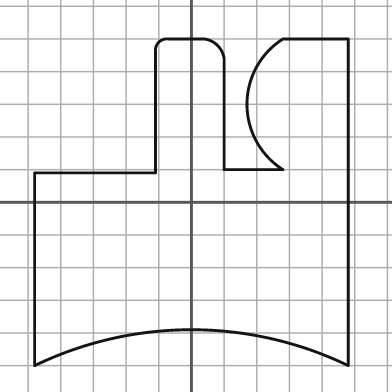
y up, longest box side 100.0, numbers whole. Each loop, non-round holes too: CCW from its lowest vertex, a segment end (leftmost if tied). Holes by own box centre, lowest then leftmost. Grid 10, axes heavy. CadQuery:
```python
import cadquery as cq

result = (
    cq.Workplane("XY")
    .moveTo(-48.0, -50.0)
    .threePointArc((0.0, -39.0), (48.0, -50.0))
    .lineTo(48.0, 50.0)
    .lineTo(28.0, 50.0)
    .threePointArc((17.0, 30.0), (28.0, 10.0))
    .lineTo(10.0, 10.0)
    .lineTo(10.0, 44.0)
    .threePointArc((8.0, 48.0), (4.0, 50.0))
    .lineTo(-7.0, 50.0)
    .threePointArc((-10.0, 49.0), (-11.0, 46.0))
    .lineTo(-11.0, 9.0)
    .lineTo(-48.0, 9.0)
    .close()
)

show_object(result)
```